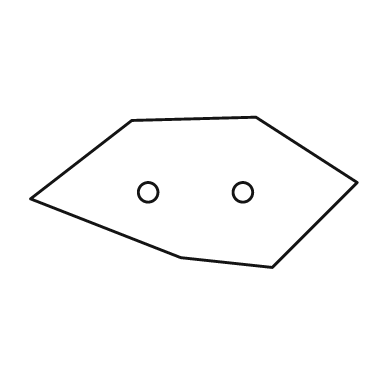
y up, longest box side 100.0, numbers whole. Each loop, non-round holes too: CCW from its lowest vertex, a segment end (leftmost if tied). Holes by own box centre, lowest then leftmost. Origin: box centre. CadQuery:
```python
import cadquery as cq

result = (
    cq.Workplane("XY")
    .moveTo(24.0, -23.0)
    .lineTo(50.0, 3.0)
    .lineTo(19.0, 23.0)
    .lineTo(-19.0, 22.0)
    .lineTo(-50.0, -2.0)
    .lineTo(-4.0, -20.0)
    .close()
    .moveTo(-14.0, 0.0)
    .circle(3.0)
    .moveTo(15.0, 0.0)
    .circle(3.0)
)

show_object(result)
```